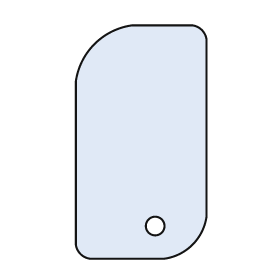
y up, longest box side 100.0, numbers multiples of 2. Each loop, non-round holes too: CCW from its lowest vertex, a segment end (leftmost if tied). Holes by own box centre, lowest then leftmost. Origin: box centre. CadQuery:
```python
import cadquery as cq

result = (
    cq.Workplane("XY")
    .moveTo(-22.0, -50.0)
    .lineTo(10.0, -50.0)
    .threePointArc((22.0, -44.0), (28.0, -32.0))
    .lineTo(28.0, 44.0)
    .threePointArc((26.0, 48.0), (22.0, 50.0))
    .lineTo(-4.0, 50.0)
    .threePointArc((-20.0, 42.0), (-28.0, 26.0))
    .lineTo(-28.0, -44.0)
    .threePointArc((-26.0, -48.0), (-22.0, -50.0))
    .close()
    .moveTo(6.0, -36.0)
    .circle(4.0)
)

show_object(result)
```